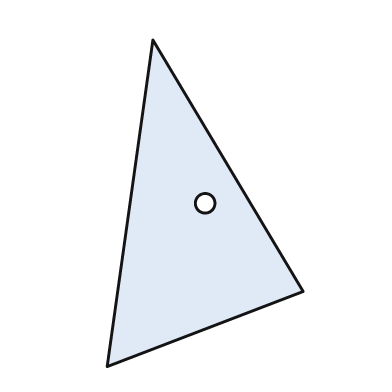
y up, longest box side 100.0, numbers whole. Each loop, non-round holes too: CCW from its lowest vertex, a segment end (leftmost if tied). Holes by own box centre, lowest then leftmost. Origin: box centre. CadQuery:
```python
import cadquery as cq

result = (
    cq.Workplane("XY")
    .moveTo(-30.0, -50.0)
    .lineTo(30.0, -27.0)
    .lineTo(-16.0, 50.0)
    .close()
    .moveTo(0.0, 0.0)
    .circle(3.0)
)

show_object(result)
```